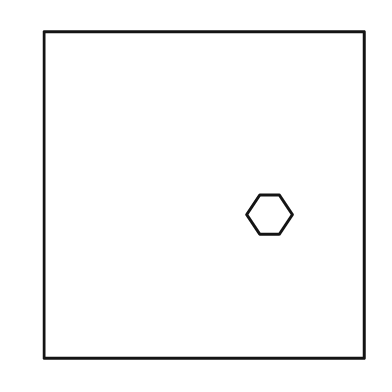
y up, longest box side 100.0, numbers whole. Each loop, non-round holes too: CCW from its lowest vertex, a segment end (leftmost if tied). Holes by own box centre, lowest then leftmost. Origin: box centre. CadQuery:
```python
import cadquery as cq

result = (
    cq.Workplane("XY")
    .moveTo(-49.0, -50.0)
    .lineTo(49.0, -50.0)
    .lineTo(49.0, 50.0)
    .lineTo(-49.0, 50.0)
    .close()
    .moveTo(17.0, -12.0)
    .lineTo(23.0, -12.0)
    .lineTo(27.0, -6.0)
    .lineTo(23.0, 0.0)
    .lineTo(17.0, 0.0)
    .lineTo(13.0, -6.0)
    .close()
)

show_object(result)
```